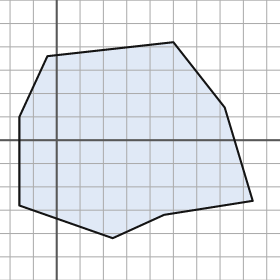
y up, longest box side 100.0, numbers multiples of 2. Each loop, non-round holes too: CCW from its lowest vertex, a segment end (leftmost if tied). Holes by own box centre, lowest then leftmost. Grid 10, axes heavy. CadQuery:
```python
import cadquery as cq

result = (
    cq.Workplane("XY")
    .moveTo(24.0, -42.0)
    .lineTo(46.0, -32.0)
    .lineTo(84.0, -26.0)
    .lineTo(72.0, 14.0)
    .lineTo(50.0, 42.0)
    .lineTo(-4.0, 36.0)
    .lineTo(-16.0, 10.0)
    .lineTo(-16.0, -28.0)
    .close()
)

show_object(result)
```